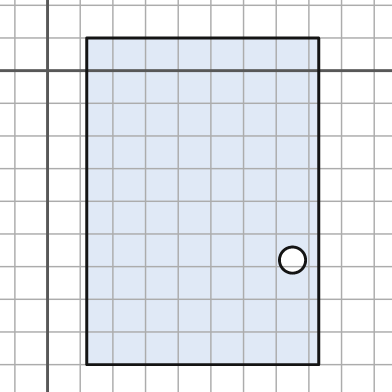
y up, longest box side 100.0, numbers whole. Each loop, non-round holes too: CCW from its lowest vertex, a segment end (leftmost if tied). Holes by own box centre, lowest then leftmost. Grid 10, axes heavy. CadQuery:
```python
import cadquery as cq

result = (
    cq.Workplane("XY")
    .moveTo(12.0, -90.0)
    .lineTo(83.0, -90.0)
    .lineTo(83.0, 10.0)
    .lineTo(12.0, 10.0)
    .close()
    .moveTo(75.0, -58.0)
    .circle(4.0)
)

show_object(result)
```